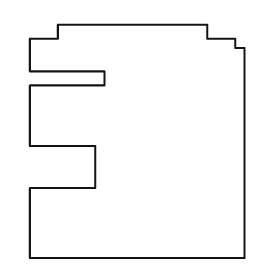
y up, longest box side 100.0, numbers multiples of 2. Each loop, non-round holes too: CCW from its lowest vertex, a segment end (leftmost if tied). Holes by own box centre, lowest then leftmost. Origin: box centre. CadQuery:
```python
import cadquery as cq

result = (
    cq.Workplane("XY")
    .moveTo(-46.0, -50.0)
    .lineTo(46.0, -50.0)
    .lineTo(46.0, 40.0)
    .lineTo(42.0, 40.0)
    .lineTo(42.0, 44.0)
    .lineTo(30.0, 44.0)
    .lineTo(30.0, 50.0)
    .lineTo(-34.0, 50.0)
    .lineTo(-34.0, 44.0)
    .lineTo(-46.0, 44.0)
    .lineTo(-46.0, 30.0)
    .lineTo(-14.0, 30.0)
    .lineTo(-14.0, 24.0)
    .lineTo(-46.0, 24.0)
    .lineTo(-46.0, -2.0)
    .lineTo(-18.0, -2.0)
    .lineTo(-18.0, -20.0)
    .lineTo(-46.0, -20.0)
    .close()
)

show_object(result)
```